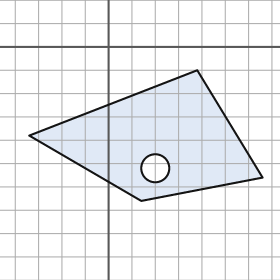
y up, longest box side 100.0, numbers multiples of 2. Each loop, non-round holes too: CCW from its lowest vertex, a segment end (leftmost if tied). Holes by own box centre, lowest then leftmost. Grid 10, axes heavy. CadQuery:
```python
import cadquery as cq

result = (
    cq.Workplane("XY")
    .moveTo(14.0, -66.0)
    .lineTo(66.0, -56.0)
    .lineTo(38.0, -10.0)
    .lineTo(-34.0, -38.0)
    .close()
    .moveTo(20.0, -52.0)
    .circle(6.0)
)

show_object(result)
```